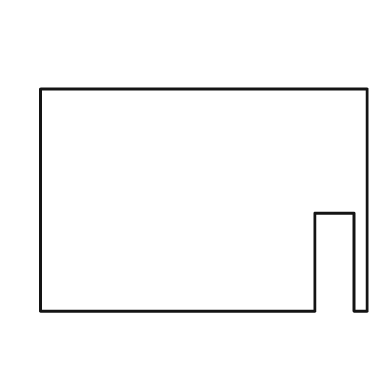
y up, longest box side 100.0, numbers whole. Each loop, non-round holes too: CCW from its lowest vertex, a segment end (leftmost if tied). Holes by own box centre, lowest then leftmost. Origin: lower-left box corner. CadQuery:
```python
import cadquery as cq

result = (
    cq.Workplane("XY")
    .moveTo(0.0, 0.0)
    .lineTo(84.0, 0.0)
    .lineTo(84.0, 30.0)
    .lineTo(96.0, 30.0)
    .lineTo(96.0, 0.0)
    .lineTo(100.0, 0.0)
    .lineTo(100.0, 68.0)
    .lineTo(0.0, 68.0)
    .close()
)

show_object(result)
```